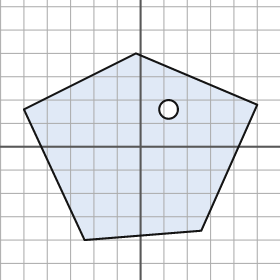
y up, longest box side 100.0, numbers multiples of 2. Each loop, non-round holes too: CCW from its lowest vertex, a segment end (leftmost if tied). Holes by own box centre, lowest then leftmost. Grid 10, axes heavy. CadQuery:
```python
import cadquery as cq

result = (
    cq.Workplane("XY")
    .moveTo(-24.0, -40.0)
    .lineTo(26.0, -36.0)
    .lineTo(50.0, 18.0)
    .lineTo(-2.0, 40.0)
    .lineTo(-50.0, 16.0)
    .close()
    .moveTo(12.0, 16.0)
    .circle(4.0)
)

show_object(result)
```